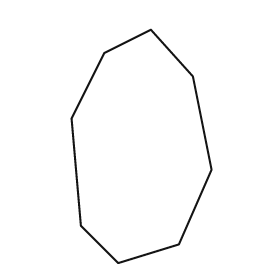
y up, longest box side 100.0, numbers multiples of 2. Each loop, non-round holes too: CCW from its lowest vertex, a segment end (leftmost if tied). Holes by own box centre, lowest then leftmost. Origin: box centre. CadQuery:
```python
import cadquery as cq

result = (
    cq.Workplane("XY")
    .moveTo(-10.0, -50.0)
    .lineTo(16.0, -42.0)
    .lineTo(30.0, -10.0)
    .lineTo(22.0, 30.0)
    .lineTo(4.0, 50.0)
    .lineTo(-16.0, 40.0)
    .lineTo(-30.0, 12.0)
    .lineTo(-26.0, -34.0)
    .close()
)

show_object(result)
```